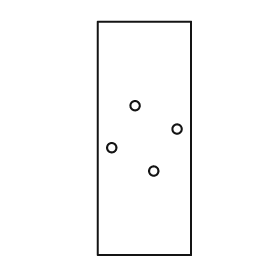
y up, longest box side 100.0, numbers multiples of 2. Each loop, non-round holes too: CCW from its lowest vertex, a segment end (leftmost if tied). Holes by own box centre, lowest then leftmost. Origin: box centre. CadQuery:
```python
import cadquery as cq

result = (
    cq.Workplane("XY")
    .moveTo(-20.0, -50.0)
    .lineTo(20.0, -50.0)
    .lineTo(20.0, 50.0)
    .lineTo(-20.0, 50.0)
    .close()
    .moveTo(4.0, -14.0)
    .circle(2.0)
    .moveTo(-14.0, -4.0)
    .circle(2.0)
    .moveTo(14.0, 4.0)
    .circle(2.0)
    .moveTo(-4.0, 14.0)
    .circle(2.0)
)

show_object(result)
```